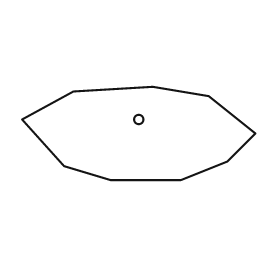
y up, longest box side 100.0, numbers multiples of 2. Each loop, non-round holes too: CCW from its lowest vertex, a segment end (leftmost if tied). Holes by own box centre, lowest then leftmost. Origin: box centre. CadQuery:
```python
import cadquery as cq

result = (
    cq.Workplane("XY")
    .moveTo(-12.0, -20.0)
    .lineTo(18.0, -20.0)
    .lineTo(38.0, -12.0)
    .lineTo(50.0, 0.0)
    .lineTo(30.0, 16.0)
    .lineTo(6.0, 20.0)
    .lineTo(-28.0, 18.0)
    .lineTo(-50.0, 6.0)
    .lineTo(-32.0, -14.0)
    .close()
    .moveTo(0.0, 6.0)
    .circle(2.0)
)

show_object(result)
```